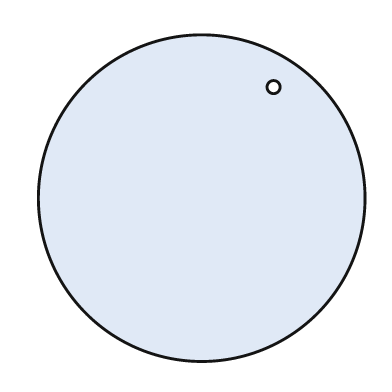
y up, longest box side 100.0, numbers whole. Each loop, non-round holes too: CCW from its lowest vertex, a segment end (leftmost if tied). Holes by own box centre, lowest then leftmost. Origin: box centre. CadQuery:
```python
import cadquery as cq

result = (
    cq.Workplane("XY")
    .moveTo(0.0, 0.0)
    .circle(50.0)
    .moveTo(22.0, 34.0)
    .circle(2.0)
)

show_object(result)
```